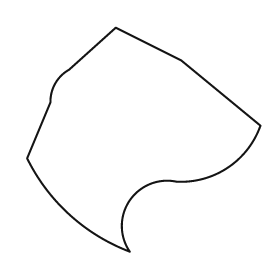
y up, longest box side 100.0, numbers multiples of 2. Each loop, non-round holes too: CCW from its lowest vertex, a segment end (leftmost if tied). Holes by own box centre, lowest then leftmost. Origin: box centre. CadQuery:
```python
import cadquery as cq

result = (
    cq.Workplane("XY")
    .moveTo(-6.0, -48.0)
    .threePointArc((-6.0, -26.0), (14.0, -18.0))
    .threePointArc((36.0, -12.0), (50.0, 6.0))
    .lineTo(16.0, 34.0)
    .lineTo(-12.0, 48.0)
    .lineTo(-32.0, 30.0)
    .threePointArc((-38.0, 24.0), (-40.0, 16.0))
    .lineTo(-50.0, -8.0)
    .threePointArc((-32.0, -32.0), (-6.0, -48.0))
    .close()
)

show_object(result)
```